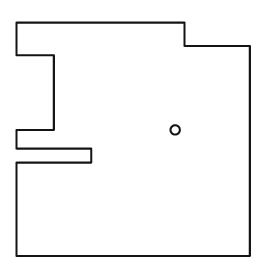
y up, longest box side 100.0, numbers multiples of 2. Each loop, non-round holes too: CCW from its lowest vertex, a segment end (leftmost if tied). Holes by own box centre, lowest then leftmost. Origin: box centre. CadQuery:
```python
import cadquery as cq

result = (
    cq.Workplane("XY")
    .moveTo(-50.0, -50.0)
    .lineTo(50.0, -50.0)
    .lineTo(50.0, 40.0)
    .lineTo(22.0, 40.0)
    .lineTo(22.0, 50.0)
    .lineTo(-50.0, 50.0)
    .lineTo(-50.0, 36.0)
    .lineTo(-34.0, 36.0)
    .lineTo(-34.0, 4.0)
    .lineTo(-50.0, 4.0)
    .lineTo(-50.0, -4.0)
    .lineTo(-18.0, -4.0)
    .lineTo(-18.0, -10.0)
    .lineTo(-50.0, -10.0)
    .close()
    .moveTo(18.0, 4.0)
    .circle(2.0)
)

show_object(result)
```